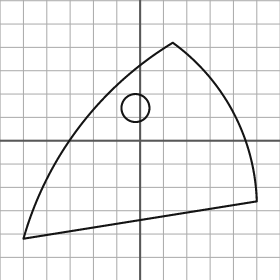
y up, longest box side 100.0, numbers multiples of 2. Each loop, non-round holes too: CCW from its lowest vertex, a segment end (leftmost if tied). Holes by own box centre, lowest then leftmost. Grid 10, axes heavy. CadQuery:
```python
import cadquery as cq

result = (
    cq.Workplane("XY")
    .moveTo(-50.0, -42.0)
    .lineTo(50.0, -26.0)
    .threePointArc((40.0, 12.0), (14.0, 42.0))
    .threePointArc((-26.0, 6.0), (-50.0, -42.0))
    .close()
    .moveTo(-2.0, 14.0)
    .circle(6.0)
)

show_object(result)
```